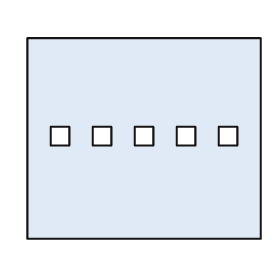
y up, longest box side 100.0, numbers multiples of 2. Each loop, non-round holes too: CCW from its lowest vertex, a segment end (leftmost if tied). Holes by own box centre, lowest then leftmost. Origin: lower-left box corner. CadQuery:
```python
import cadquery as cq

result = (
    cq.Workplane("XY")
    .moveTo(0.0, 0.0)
    .lineTo(100.0, 0.0)
    .lineTo(100.0, 86.0)
    .lineTo(0.0, 86.0)
    .close()
    .moveTo(10.0, 40.0)
    .lineTo(18.0, 40.0)
    .lineTo(18.0, 48.0)
    .lineTo(10.0, 48.0)
    .close()
    .moveTo(28.0, 40.0)
    .lineTo(36.0, 40.0)
    .lineTo(36.0, 48.0)
    .lineTo(28.0, 48.0)
    .close()
    .moveTo(46.0, 40.0)
    .lineTo(54.0, 40.0)
    .lineTo(54.0, 48.0)
    .lineTo(46.0, 48.0)
    .close()
    .moveTo(64.0, 40.0)
    .lineTo(72.0, 40.0)
    .lineTo(72.0, 48.0)
    .lineTo(64.0, 48.0)
    .close()
    .moveTo(82.0, 40.0)
    .lineTo(90.0, 40.0)
    .lineTo(90.0, 48.0)
    .lineTo(82.0, 48.0)
    .close()
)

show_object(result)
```